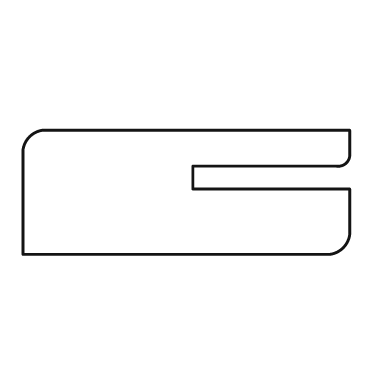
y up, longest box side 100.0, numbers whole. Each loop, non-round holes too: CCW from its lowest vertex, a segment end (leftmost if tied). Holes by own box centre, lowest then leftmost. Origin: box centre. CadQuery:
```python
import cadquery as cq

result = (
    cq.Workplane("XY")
    .moveTo(-50.0, -19.0)
    .lineTo(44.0, -19.0)
    .threePointArc((48.0, -17.0), (50.0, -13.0))
    .lineTo(50.0, 1.0)
    .lineTo(2.0, 1.0)
    .lineTo(2.0, 8.0)
    .lineTo(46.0, 8.0)
    .threePointArc((49.0, 9.0), (50.0, 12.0))
    .lineTo(50.0, 19.0)
    .lineTo(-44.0, 19.0)
    .threePointArc((-48.0, 17.0), (-50.0, 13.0))
    .close()
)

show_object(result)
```